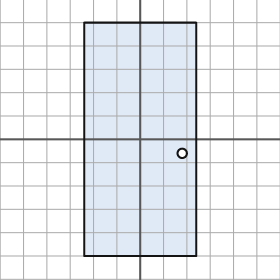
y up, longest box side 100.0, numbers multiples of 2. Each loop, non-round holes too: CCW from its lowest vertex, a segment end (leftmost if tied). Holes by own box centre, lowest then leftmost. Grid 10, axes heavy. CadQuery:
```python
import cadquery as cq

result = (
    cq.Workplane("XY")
    .moveTo(-24.0, -50.0)
    .lineTo(24.0, -50.0)
    .lineTo(24.0, 50.0)
    .lineTo(-24.0, 50.0)
    .close()
    .moveTo(18.0, -6.0)
    .circle(2.0)
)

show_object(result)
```